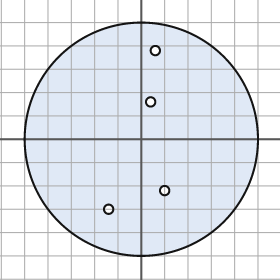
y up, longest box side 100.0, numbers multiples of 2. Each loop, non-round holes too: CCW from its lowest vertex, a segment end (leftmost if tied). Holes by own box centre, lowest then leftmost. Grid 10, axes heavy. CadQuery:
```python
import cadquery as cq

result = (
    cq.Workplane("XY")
    .moveTo(0.0, 0.0)
    .circle(50.0)
    .moveTo(-14.0, -30.0)
    .circle(2.0)
    .moveTo(10.0, -22.0)
    .circle(2.0)
    .moveTo(4.0, 16.0)
    .circle(2.0)
    .moveTo(6.0, 38.0)
    .circle(2.0)
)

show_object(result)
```